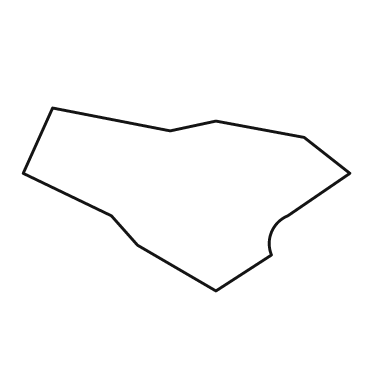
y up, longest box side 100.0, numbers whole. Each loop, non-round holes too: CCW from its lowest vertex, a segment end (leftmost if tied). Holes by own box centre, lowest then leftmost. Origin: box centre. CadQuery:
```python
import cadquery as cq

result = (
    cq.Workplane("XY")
    .moveTo(9.0, -28.0)
    .lineTo(26.0, -17.0)
    .threePointArc((26.0, -10.0), (31.0, -5.0))
    .lineTo(50.0, 8.0)
    .lineTo(36.0, 19.0)
    .lineTo(9.0, 24.0)
    .lineTo(-5.0, 21.0)
    .lineTo(-41.0, 28.0)
    .lineTo(-50.0, 8.0)
    .lineTo(-23.0, -5.0)
    .lineTo(-15.0, -14.0)
    .close()
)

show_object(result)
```